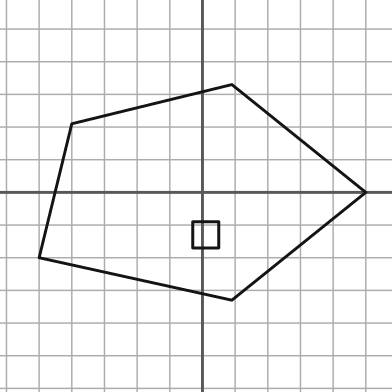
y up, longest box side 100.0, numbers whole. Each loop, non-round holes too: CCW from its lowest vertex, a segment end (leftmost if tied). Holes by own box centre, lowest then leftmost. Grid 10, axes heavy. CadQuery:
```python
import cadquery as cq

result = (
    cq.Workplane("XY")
    .moveTo(9.0, -33.0)
    .lineTo(50.0, 0.0)
    .lineTo(9.0, 33.0)
    .lineTo(-40.0, 21.0)
    .lineTo(-50.0, -20.0)
    .close()
    .moveTo(-3.0, -17.0)
    .lineTo(5.0, -17.0)
    .lineTo(5.0, -9.0)
    .lineTo(-3.0, -9.0)
    .close()
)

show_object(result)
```